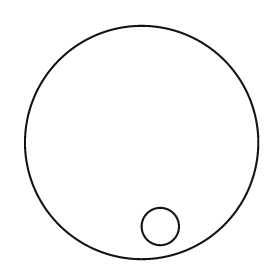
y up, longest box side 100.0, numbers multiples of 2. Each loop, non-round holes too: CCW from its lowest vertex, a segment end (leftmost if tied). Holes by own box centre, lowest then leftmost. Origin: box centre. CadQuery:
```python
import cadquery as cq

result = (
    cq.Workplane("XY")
    .moveTo(0.0, 0.0)
    .circle(50.0)
    .moveTo(8.0, -36.0)
    .circle(8.0)
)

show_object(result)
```